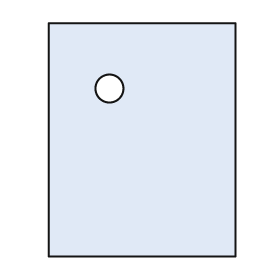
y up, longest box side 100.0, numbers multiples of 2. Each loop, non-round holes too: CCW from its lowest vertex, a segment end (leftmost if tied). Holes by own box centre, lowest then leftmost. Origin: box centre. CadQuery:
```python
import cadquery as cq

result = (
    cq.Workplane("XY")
    .moveTo(-40.0, -50.0)
    .lineTo(40.0, -50.0)
    .lineTo(40.0, 50.0)
    .lineTo(-40.0, 50.0)
    .close()
    .moveTo(-14.0, 22.0)
    .circle(6.0)
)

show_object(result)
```